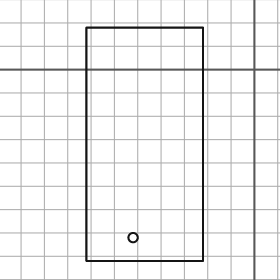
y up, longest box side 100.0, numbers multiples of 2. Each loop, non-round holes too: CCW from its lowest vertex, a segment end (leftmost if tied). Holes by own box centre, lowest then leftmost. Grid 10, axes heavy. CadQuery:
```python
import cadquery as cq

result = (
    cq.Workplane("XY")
    .moveTo(-72.0, -82.0)
    .lineTo(-22.0, -82.0)
    .lineTo(-22.0, 18.0)
    .lineTo(-72.0, 18.0)
    .close()
    .moveTo(-52.0, -72.0)
    .circle(2.0)
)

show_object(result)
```